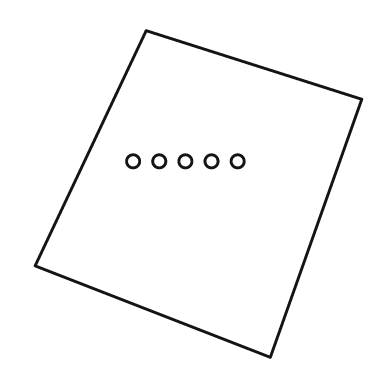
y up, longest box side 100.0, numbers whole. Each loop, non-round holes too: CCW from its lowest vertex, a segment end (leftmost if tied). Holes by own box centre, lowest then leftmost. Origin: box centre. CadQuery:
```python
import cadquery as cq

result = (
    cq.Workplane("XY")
    .moveTo(22.0, -50.0)
    .lineTo(50.0, 29.0)
    .lineTo(-16.0, 50.0)
    .lineTo(-50.0, -22.0)
    .close()
    .moveTo(-20.0, 10.0)
    .circle(2.0)
    .moveTo(-12.0, 10.0)
    .circle(2.0)
    .moveTo(-4.0, 10.0)
    .circle(2.0)
    .moveTo(4.0, 10.0)
    .circle(2.0)
    .moveTo(12.0, 10.0)
    .circle(2.0)
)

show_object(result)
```